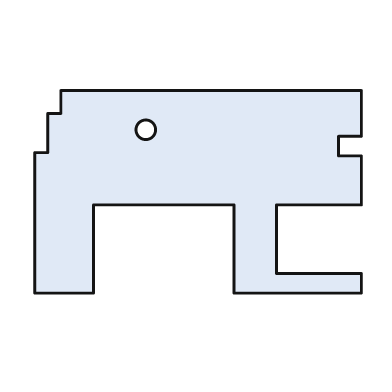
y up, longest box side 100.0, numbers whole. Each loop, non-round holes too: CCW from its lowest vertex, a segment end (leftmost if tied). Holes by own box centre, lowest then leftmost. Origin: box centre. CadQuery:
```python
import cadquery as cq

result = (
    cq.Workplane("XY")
    .moveTo(-50.0, -31.0)
    .lineTo(-32.0, -31.0)
    .lineTo(-32.0, -4.0)
    .lineTo(11.0, -4.0)
    .lineTo(11.0, -31.0)
    .lineTo(50.0, -31.0)
    .lineTo(50.0, -25.0)
    .lineTo(24.0, -25.0)
    .lineTo(24.0, -4.0)
    .lineTo(50.0, -4.0)
    .lineTo(50.0, 11.0)
    .lineTo(43.0, 11.0)
    .lineTo(43.0, 17.0)
    .lineTo(50.0, 17.0)
    .lineTo(50.0, 31.0)
    .lineTo(-42.0, 31.0)
    .lineTo(-42.0, 24.0)
    .lineTo(-46.0, 24.0)
    .lineTo(-46.0, 12.0)
    .lineTo(-50.0, 12.0)
    .close()
    .moveTo(-16.0, 19.0)
    .circle(3.0)
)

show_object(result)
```